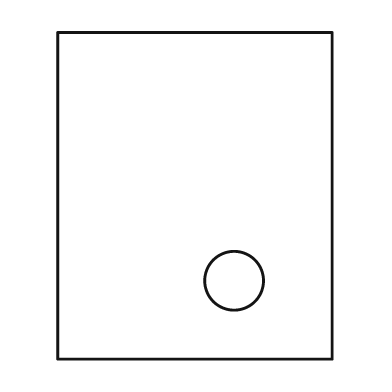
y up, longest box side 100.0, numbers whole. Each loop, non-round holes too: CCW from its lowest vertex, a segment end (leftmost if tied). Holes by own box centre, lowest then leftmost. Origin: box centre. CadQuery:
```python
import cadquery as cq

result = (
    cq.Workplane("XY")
    .moveTo(-42.0, -50.0)
    .lineTo(42.0, -50.0)
    .lineTo(42.0, 50.0)
    .lineTo(-42.0, 50.0)
    .close()
    .moveTo(12.0, -26.0)
    .circle(9.0)
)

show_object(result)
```